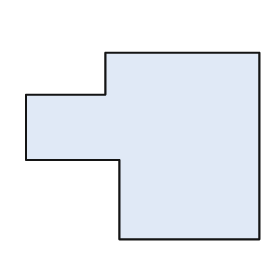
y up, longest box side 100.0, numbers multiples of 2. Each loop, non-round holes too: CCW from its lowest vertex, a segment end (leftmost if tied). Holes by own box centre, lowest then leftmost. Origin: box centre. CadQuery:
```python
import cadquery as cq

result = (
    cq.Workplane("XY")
    .moveTo(-10.0, -40.0)
    .lineTo(50.0, -40.0)
    .lineTo(50.0, 40.0)
    .lineTo(-16.0, 40.0)
    .lineTo(-16.0, 22.0)
    .lineTo(-50.0, 22.0)
    .lineTo(-50.0, -6.0)
    .lineTo(-10.0, -6.0)
    .close()
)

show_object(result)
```